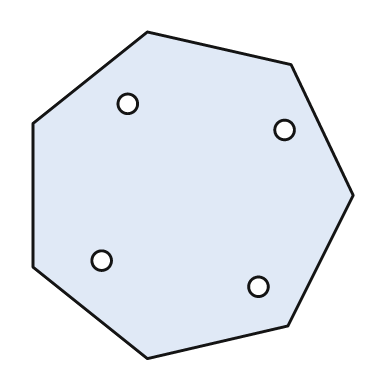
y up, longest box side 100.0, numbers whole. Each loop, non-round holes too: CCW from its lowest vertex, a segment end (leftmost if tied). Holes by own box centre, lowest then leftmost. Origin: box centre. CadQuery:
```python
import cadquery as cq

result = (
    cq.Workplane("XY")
    .moveTo(-14.0, -50.0)
    .lineTo(29.0, -40.0)
    .lineTo(49.0, 0.0)
    .lineTo(30.0, 40.0)
    .lineTo(-14.0, 50.0)
    .lineTo(-49.0, 22.0)
    .lineTo(-49.0, -22.0)
    .close()
    .moveTo(20.0, -28.0)
    .circle(3.0)
    .moveTo(-28.0, -20.0)
    .circle(3.0)
    .moveTo(28.0, 20.0)
    .circle(3.0)
    .moveTo(-20.0, 28.0)
    .circle(3.0)
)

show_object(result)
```